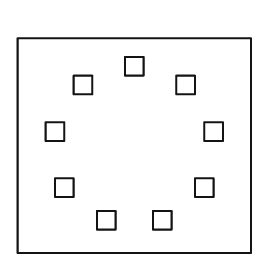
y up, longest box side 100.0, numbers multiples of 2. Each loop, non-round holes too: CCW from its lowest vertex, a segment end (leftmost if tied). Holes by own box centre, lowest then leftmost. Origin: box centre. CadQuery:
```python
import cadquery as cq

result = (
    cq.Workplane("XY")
    .moveTo(-50.0, -46.0)
    .lineTo(50.0, -46.0)
    .lineTo(50.0, 46.0)
    .lineTo(-50.0, 46.0)
    .close()
    .moveTo(-16.0, -36.0)
    .lineTo(-8.0, -36.0)
    .lineTo(-8.0, -28.0)
    .lineTo(-16.0, -28.0)
    .close()
    .moveTo(8.0, -36.0)
    .lineTo(16.0, -36.0)
    .lineTo(16.0, -28.0)
    .lineTo(8.0, -28.0)
    .close()
    .moveTo(-34.0, -22.0)
    .lineTo(-26.0, -22.0)
    .lineTo(-26.0, -14.0)
    .lineTo(-34.0, -14.0)
    .close()
    .moveTo(26.0, -22.0)
    .lineTo(34.0, -22.0)
    .lineTo(34.0, -14.0)
    .lineTo(26.0, -14.0)
    .close()
    .moveTo(-38.0, 2.0)
    .lineTo(-30.0, 2.0)
    .lineTo(-30.0, 10.0)
    .lineTo(-38.0, 10.0)
    .close()
    .moveTo(30.0, 2.0)
    .lineTo(38.0, 2.0)
    .lineTo(38.0, 10.0)
    .lineTo(30.0, 10.0)
    .close()
    .moveTo(-26.0, 22.0)
    .lineTo(-18.0, 22.0)
    .lineTo(-18.0, 30.0)
    .lineTo(-26.0, 30.0)
    .close()
    .moveTo(18.0, 22.0)
    .lineTo(26.0, 22.0)
    .lineTo(26.0, 30.0)
    .lineTo(18.0, 30.0)
    .close()
    .moveTo(-4.0, 30.0)
    .lineTo(4.0, 30.0)
    .lineTo(4.0, 38.0)
    .lineTo(-4.0, 38.0)
    .close()
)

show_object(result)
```